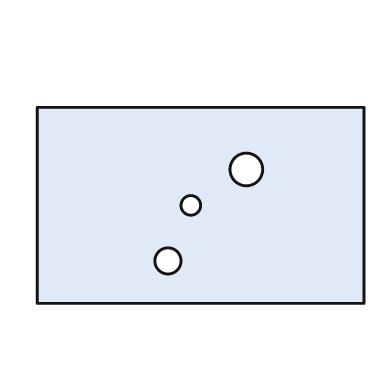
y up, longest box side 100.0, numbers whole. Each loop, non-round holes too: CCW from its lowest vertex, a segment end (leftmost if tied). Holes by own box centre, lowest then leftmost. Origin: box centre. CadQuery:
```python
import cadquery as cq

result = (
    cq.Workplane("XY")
    .moveTo(-50.0, -30.0)
    .lineTo(50.0, -30.0)
    .lineTo(50.0, 30.0)
    .lineTo(-50.0, 30.0)
    .close()
    .moveTo(-10.0, -17.0)
    .circle(4.0)
    .moveTo(-3.0, 0.0)
    .circle(3.0)
    .moveTo(14.0, 11.0)
    .circle(5.0)
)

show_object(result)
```